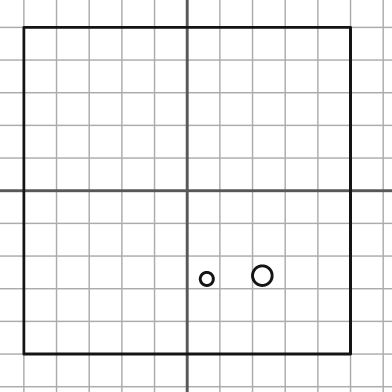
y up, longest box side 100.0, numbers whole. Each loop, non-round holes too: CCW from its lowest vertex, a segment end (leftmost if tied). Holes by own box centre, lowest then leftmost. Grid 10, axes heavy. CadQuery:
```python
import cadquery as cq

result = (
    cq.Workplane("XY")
    .moveTo(-50.0, -50.0)
    .lineTo(50.0, -50.0)
    .lineTo(50.0, 50.0)
    .lineTo(-50.0, 50.0)
    .close()
    .moveTo(6.0, -27.0)
    .circle(2.0)
    .moveTo(23.0, -26.0)
    .circle(3.0)
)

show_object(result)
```